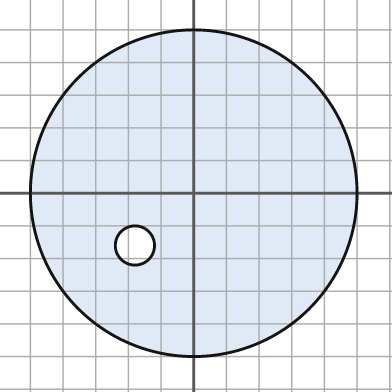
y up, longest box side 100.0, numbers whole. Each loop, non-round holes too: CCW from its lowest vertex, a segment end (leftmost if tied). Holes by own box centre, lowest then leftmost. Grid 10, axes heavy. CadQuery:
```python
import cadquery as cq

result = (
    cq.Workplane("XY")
    .moveTo(0.0, 0.0)
    .circle(50.0)
    .moveTo(-18.0, -16.0)
    .circle(6.0)
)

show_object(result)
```